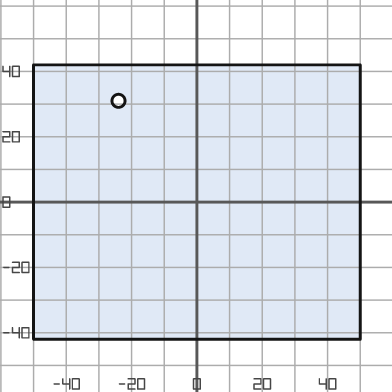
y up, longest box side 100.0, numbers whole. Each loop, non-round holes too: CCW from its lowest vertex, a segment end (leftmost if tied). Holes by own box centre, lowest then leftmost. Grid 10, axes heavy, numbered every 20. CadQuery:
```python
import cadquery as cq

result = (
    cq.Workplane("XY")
    .moveTo(-50.0, -42.0)
    .lineTo(50.0, -42.0)
    .lineTo(50.0, 42.0)
    .lineTo(-50.0, 42.0)
    .close()
    .moveTo(-24.0, 31.0)
    .circle(2.0)
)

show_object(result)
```